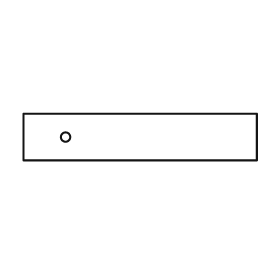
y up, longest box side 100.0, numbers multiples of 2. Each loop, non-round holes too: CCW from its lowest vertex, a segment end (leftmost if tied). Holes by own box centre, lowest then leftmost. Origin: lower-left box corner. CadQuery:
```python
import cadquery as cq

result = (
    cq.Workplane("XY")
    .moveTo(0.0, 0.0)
    .lineTo(100.0, 0.0)
    .lineTo(100.0, 20.0)
    .lineTo(0.0, 20.0)
    .close()
    .moveTo(18.0, 10.0)
    .circle(2.0)
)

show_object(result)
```